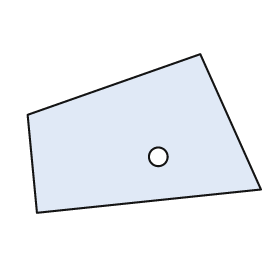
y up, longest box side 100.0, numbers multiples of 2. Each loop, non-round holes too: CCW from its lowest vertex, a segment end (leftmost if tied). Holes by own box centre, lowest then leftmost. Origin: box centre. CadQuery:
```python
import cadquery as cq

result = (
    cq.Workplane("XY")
    .moveTo(-46.0, -34.0)
    .lineTo(50.0, -24.0)
    .lineTo(24.0, 34.0)
    .lineTo(-50.0, 8.0)
    .close()
    .moveTo(6.0, -10.0)
    .circle(4.0)
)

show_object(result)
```